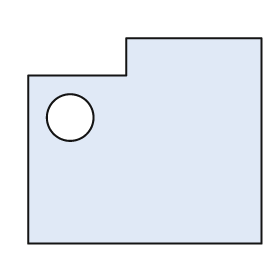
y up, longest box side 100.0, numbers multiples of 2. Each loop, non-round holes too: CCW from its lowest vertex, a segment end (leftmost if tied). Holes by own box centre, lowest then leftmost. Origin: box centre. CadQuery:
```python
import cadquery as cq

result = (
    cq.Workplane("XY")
    .moveTo(-50.0, -44.0)
    .lineTo(50.0, -44.0)
    .lineTo(50.0, 44.0)
    .lineTo(-8.0, 44.0)
    .lineTo(-8.0, 28.0)
    .lineTo(-50.0, 28.0)
    .close()
    .moveTo(-32.0, 10.0)
    .circle(10.0)
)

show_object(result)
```